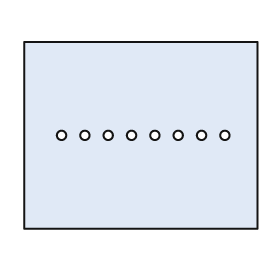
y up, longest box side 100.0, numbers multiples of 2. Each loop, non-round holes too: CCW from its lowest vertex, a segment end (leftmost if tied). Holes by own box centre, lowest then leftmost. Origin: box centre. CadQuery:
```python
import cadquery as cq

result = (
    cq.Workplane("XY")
    .moveTo(-50.0, -40.0)
    .lineTo(50.0, -40.0)
    .lineTo(50.0, 40.0)
    .lineTo(-50.0, 40.0)
    .close()
    .moveTo(-34.0, 0.0)
    .circle(2.0)
    .moveTo(-24.0, 0.0)
    .circle(2.0)
    .moveTo(-14.0, 0.0)
    .circle(2.0)
    .moveTo(-4.0, 0.0)
    .circle(2.0)
    .moveTo(6.0, 0.0)
    .circle(2.0)
    .moveTo(16.0, 0.0)
    .circle(2.0)
    .moveTo(26.0, 0.0)
    .circle(2.0)
    .moveTo(36.0, 0.0)
    .circle(2.0)
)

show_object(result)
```